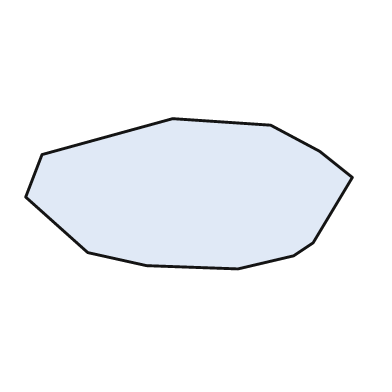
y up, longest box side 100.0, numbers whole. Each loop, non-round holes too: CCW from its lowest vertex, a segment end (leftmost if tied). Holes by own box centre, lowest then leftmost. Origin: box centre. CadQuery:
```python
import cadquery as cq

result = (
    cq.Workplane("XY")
    .moveTo(15.0, -23.0)
    .lineTo(32.0, -19.0)
    .lineTo(38.0, -15.0)
    .lineTo(50.0, 5.0)
    .lineTo(40.0, 13.0)
    .lineTo(25.0, 21.0)
    .lineTo(-5.0, 23.0)
    .lineTo(-45.0, 12.0)
    .lineTo(-50.0, -1.0)
    .lineTo(-31.0, -18.0)
    .lineTo(-13.0, -22.0)
    .close()
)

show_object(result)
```